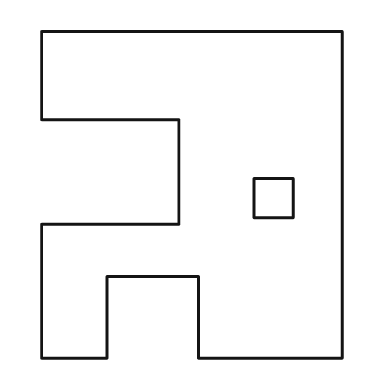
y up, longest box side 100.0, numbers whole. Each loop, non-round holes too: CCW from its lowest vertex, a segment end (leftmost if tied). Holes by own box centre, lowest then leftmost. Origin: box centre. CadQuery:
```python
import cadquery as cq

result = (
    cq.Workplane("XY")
    .moveTo(-46.0, -50.0)
    .lineTo(-26.0, -50.0)
    .lineTo(-26.0, -25.0)
    .lineTo(2.0, -25.0)
    .lineTo(2.0, -50.0)
    .lineTo(46.0, -50.0)
    .lineTo(46.0, 50.0)
    .lineTo(-46.0, 50.0)
    .lineTo(-46.0, 23.0)
    .lineTo(-4.0, 23.0)
    .lineTo(-4.0, -9.0)
    .lineTo(-46.0, -9.0)
    .close()
    .moveTo(19.0, -7.0)
    .lineTo(31.0, -7.0)
    .lineTo(31.0, 5.0)
    .lineTo(19.0, 5.0)
    .close()
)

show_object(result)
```